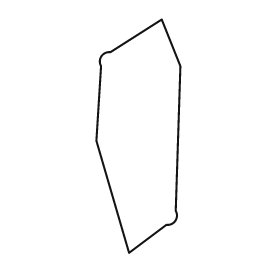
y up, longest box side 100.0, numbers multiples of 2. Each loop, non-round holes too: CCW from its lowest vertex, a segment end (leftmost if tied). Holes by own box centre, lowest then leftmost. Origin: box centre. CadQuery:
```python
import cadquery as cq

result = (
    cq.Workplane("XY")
    .moveTo(-4.0, -50.0)
    .lineTo(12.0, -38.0)
    .threePointArc((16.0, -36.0), (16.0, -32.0))
    .lineTo(18.0, 30.0)
    .lineTo(10.0, 50.0)
    .lineTo(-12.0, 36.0)
    .threePointArc((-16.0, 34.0), (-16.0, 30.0))
    .lineTo(-18.0, -2.0)
    .close()
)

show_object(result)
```